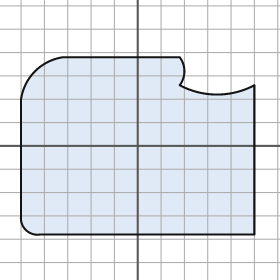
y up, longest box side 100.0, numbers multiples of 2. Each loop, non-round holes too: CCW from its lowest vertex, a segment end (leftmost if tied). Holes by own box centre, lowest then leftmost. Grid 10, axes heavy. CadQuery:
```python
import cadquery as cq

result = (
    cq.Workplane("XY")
    .moveTo(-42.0, -38.0)
    .lineTo(50.0, -38.0)
    .lineTo(50.0, 26.0)
    .threePointArc((34.0, 22.0), (18.0, 26.0))
    .threePointArc((20.0, 32.0), (18.0, 38.0))
    .lineTo(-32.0, 38.0)
    .threePointArc((-44.0, 32.0), (-50.0, 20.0))
    .lineTo(-50.0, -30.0)
    .threePointArc((-48.0, -36.0), (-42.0, -38.0))
    .close()
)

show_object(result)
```